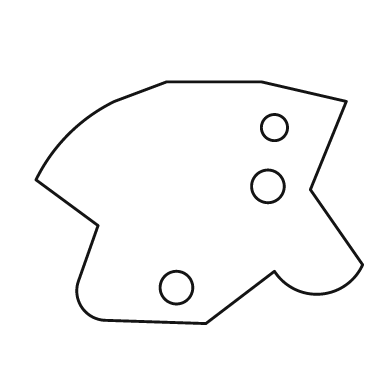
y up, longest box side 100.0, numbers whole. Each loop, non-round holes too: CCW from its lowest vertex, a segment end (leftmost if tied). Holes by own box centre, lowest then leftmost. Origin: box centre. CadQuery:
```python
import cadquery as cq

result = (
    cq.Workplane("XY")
    .moveTo(2.0, -37.0)
    .lineTo(23.0, -21.0)
    .threePointArc((37.0, -28.0), (50.0, -19.0))
    .lineTo(34.0, 4.0)
    .lineTo(45.0, 31.0)
    .lineTo(19.0, 37.0)
    .lineTo(-10.0, 37.0)
    .lineTo(-26.0, 31.0)
    .threePointArc((-40.0, 21.0), (-50.0, 7.0))
    .lineTo(-31.0, -7.0)
    .lineTo(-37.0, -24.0)
    .threePointArc((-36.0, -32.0), (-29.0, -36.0))
    .close()
    .moveTo(-7.0, -26.0)
    .circle(5.0)
    .moveTo(21.0, 5.0)
    .circle(5.0)
    .moveTo(23.0, 23.0)
    .circle(4.0)
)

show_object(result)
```